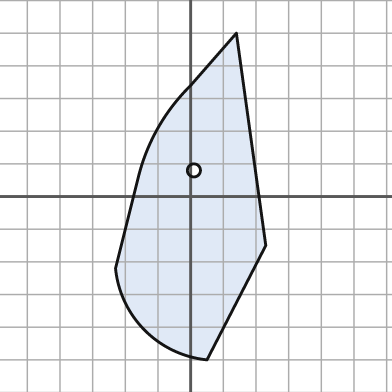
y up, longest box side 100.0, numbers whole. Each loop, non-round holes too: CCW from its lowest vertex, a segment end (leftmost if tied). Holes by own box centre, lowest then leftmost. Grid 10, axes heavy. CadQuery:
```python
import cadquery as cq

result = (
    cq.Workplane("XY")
    .moveTo(5.0, -50.0)
    .lineTo(23.0, -15.0)
    .lineTo(14.0, 50.0)
    .lineTo(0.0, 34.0)
    .threePointArc((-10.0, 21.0), (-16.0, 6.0))
    .lineTo(-23.0, -22.0)
    .threePointArc((-14.0, -41.0), (5.0, -50.0))
    .close()
    .moveTo(1.0, 8.0)
    .circle(2.0)
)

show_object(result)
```